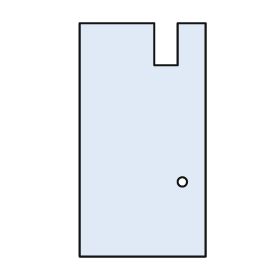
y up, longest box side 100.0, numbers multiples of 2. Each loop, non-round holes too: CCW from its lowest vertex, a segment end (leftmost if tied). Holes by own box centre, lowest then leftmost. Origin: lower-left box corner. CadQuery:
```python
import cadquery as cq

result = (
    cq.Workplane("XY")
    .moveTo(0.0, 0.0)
    .lineTo(54.0, 0.0)
    .lineTo(54.0, 100.0)
    .lineTo(42.0, 100.0)
    .lineTo(42.0, 82.0)
    .lineTo(32.0, 82.0)
    .lineTo(32.0, 100.0)
    .lineTo(0.0, 100.0)
    .close()
    .moveTo(44.0, 32.0)
    .circle(2.0)
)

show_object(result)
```